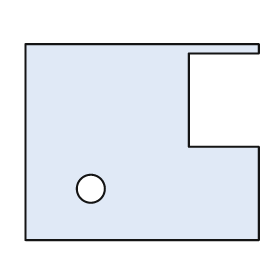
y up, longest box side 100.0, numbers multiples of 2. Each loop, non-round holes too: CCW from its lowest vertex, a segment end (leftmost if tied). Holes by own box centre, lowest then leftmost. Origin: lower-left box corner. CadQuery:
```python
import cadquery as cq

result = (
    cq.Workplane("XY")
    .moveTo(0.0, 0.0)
    .lineTo(100.0, 0.0)
    .lineTo(100.0, 40.0)
    .lineTo(70.0, 40.0)
    .lineTo(70.0, 80.0)
    .lineTo(100.0, 80.0)
    .lineTo(100.0, 84.0)
    .lineTo(0.0, 84.0)
    .close()
    .moveTo(28.0, 22.0)
    .circle(6.0)
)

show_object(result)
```